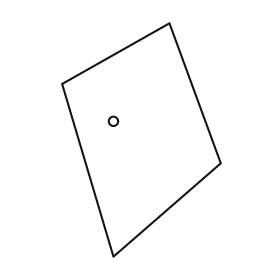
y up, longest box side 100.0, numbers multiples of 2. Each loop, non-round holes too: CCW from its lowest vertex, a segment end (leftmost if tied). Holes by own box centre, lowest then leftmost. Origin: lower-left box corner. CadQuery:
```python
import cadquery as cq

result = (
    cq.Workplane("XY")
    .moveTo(22.0, 0.0)
    .lineTo(68.0, 40.0)
    .lineTo(46.0, 100.0)
    .lineTo(0.0, 74.0)
    .close()
    .moveTo(22.0, 58.0)
    .circle(2.0)
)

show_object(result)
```